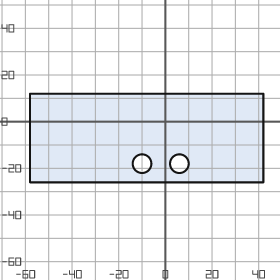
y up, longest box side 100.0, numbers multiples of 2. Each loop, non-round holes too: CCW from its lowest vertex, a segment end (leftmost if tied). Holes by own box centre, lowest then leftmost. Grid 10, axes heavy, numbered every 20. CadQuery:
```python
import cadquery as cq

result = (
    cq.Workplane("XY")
    .moveTo(-58.0, -26.0)
    .lineTo(42.0, -26.0)
    .lineTo(42.0, 12.0)
    .lineTo(-58.0, 12.0)
    .close()
    .moveTo(-10.0, -18.0)
    .circle(4.0)
    .moveTo(6.0, -18.0)
    .circle(4.0)
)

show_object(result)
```